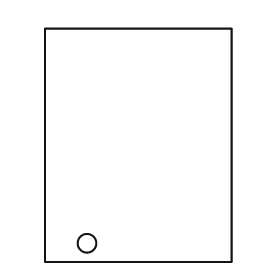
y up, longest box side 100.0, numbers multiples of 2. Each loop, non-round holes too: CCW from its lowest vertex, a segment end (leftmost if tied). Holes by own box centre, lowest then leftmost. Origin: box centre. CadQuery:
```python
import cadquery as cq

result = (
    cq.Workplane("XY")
    .moveTo(-40.0, -50.0)
    .lineTo(40.0, -50.0)
    .lineTo(40.0, 50.0)
    .lineTo(-40.0, 50.0)
    .close()
    .moveTo(-22.0, -42.0)
    .circle(4.0)
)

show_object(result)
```